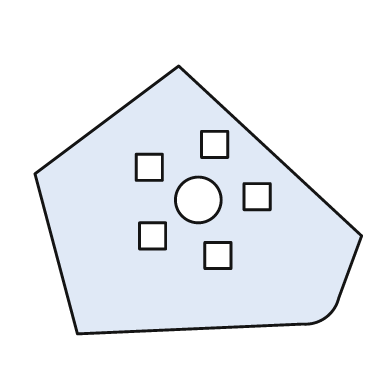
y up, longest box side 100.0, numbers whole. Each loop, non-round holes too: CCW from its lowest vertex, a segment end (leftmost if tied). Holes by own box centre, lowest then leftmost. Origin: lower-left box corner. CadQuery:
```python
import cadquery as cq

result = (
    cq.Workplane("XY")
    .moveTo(13.0, 0.0)
    .lineTo(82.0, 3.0)
    .threePointArc((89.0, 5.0), (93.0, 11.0))
    .lineTo(100.0, 30.0)
    .lineTo(44.0, 82.0)
    .lineTo(0.0, 49.0)
    .close()
    .moveTo(52.0, 20.0)
    .lineTo(60.0, 20.0)
    .lineTo(60.0, 28.0)
    .lineTo(52.0, 28.0)
    .close()
    .moveTo(32.0, 26.0)
    .lineTo(40.0, 26.0)
    .lineTo(40.0, 34.0)
    .lineTo(32.0, 34.0)
    .close()
    .moveTo(50.0, 41.0)
    .circle(7.0)
    .moveTo(64.0, 38.0)
    .lineTo(72.0, 38.0)
    .lineTo(72.0, 46.0)
    .lineTo(64.0, 46.0)
    .close()
    .moveTo(31.0, 47.0)
    .lineTo(39.0, 47.0)
    .lineTo(39.0, 55.0)
    .lineTo(31.0, 55.0)
    .close()
    .moveTo(51.0, 54.0)
    .lineTo(59.0, 54.0)
    .lineTo(59.0, 62.0)
    .lineTo(51.0, 62.0)
    .close()
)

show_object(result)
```